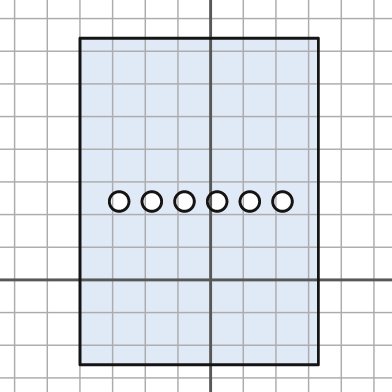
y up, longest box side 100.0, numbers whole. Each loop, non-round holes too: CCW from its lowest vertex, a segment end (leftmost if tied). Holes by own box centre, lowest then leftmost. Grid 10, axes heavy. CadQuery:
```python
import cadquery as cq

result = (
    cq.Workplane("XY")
    .moveTo(-40.0, -26.0)
    .lineTo(33.0, -26.0)
    .lineTo(33.0, 74.0)
    .lineTo(-40.0, 74.0)
    .close()
    .moveTo(-28.0, 24.0)
    .circle(3.0)
    .moveTo(-18.0, 24.0)
    .circle(3.0)
    .moveTo(-8.0, 24.0)
    .circle(3.0)
    .moveTo(2.0, 24.0)
    .circle(3.0)
    .moveTo(12.0, 24.0)
    .circle(3.0)
    .moveTo(22.0, 24.0)
    .circle(3.0)
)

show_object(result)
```